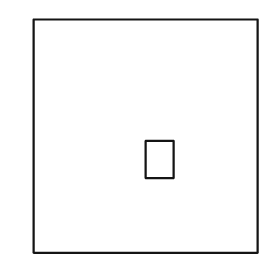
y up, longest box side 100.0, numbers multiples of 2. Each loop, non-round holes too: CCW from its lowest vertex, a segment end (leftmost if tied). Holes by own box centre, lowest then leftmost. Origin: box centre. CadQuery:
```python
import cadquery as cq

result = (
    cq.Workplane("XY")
    .moveTo(-48.0, -50.0)
    .lineTo(48.0, -50.0)
    .lineTo(48.0, 50.0)
    .lineTo(-48.0, 50.0)
    .close()
    .moveTo(0.0, -18.0)
    .lineTo(12.0, -18.0)
    .lineTo(12.0, -2.0)
    .lineTo(0.0, -2.0)
    .close()
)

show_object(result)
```